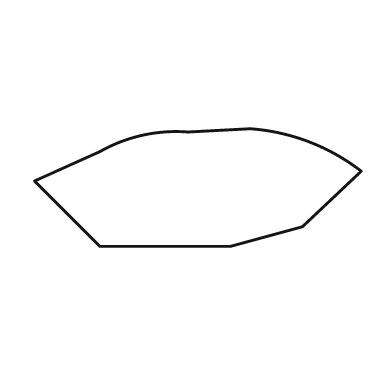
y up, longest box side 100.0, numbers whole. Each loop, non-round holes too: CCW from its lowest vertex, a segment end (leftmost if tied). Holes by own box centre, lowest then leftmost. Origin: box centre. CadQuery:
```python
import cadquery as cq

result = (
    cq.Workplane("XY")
    .moveTo(-30.0, -18.0)
    .lineTo(10.0, -18.0)
    .lineTo(32.0, -12.0)
    .lineTo(50.0, 5.0)
    .threePointArc((34.0, 14.0), (16.0, 18.0))
    .lineTo(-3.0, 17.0)
    .threePointArc((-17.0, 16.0), (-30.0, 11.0))
    .lineTo(-50.0, 2.0)
    .close()
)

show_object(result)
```